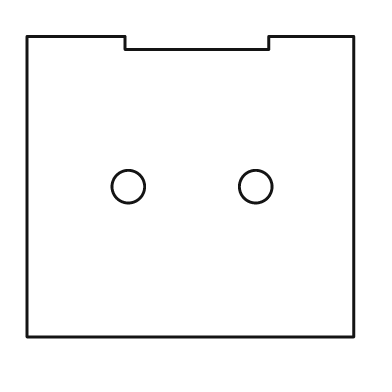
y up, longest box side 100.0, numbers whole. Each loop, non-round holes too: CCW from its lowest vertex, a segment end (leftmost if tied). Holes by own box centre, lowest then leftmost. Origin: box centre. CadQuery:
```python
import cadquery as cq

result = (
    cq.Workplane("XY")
    .moveTo(-50.0, -46.0)
    .lineTo(50.0, -46.0)
    .lineTo(50.0, 46.0)
    .lineTo(24.0, 46.0)
    .lineTo(24.0, 42.0)
    .lineTo(-20.0, 42.0)
    .lineTo(-20.0, 46.0)
    .lineTo(-50.0, 46.0)
    .close()
    .moveTo(-19.0, 0.0)
    .circle(5.0)
    .moveTo(20.0, 0.0)
    .circle(5.0)
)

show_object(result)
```